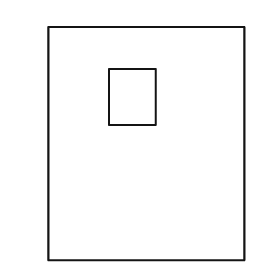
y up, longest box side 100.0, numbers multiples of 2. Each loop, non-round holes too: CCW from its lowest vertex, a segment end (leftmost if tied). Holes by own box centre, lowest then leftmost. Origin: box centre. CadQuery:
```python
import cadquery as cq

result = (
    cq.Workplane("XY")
    .moveTo(-42.0, -50.0)
    .lineTo(42.0, -50.0)
    .lineTo(42.0, 50.0)
    .lineTo(-42.0, 50.0)
    .close()
    .moveTo(-16.0, 8.0)
    .lineTo(4.0, 8.0)
    .lineTo(4.0, 32.0)
    .lineTo(-16.0, 32.0)
    .close()
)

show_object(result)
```